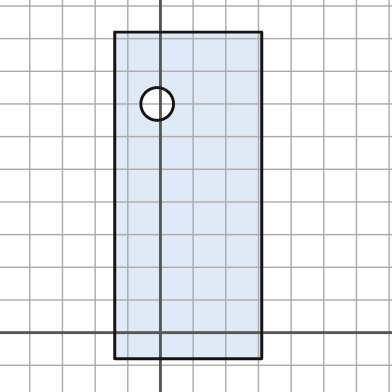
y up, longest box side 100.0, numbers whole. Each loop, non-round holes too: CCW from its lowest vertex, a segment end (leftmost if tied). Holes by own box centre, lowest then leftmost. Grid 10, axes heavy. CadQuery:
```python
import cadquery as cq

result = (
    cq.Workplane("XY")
    .moveTo(-14.0, -8.0)
    .lineTo(31.0, -8.0)
    .lineTo(31.0, 92.0)
    .lineTo(-14.0, 92.0)
    .close()
    .moveTo(-1.0, 70.0)
    .circle(5.0)
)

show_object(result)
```